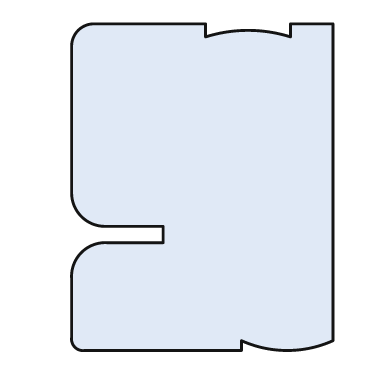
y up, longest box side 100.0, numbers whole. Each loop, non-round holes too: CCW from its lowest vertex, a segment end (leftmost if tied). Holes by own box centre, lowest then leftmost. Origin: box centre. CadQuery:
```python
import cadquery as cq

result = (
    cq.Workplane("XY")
    .moveTo(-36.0, -50.0)
    .lineTo(12.0, -50.0)
    .lineTo(12.0, -47.0)
    .threePointArc((26.0, -50.0), (40.0, -47.0))
    .lineTo(40.0, 50.0)
    .lineTo(27.0, 50.0)
    .lineTo(27.0, 46.0)
    .threePointArc((14.0, 48.0), (1.0, 46.0))
    .lineTo(1.0, 50.0)
    .lineTo(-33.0, 50.0)
    .threePointArc((-38.0, 48.0), (-40.0, 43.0))
    .lineTo(-40.0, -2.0)
    .threePointArc((-37.0, -9.0), (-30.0, -12.0))
    .lineTo(-12.0, -12.0)
    .lineTo(-12.0, -17.0)
    .lineTo(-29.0, -17.0)
    .threePointArc((-37.0, -20.0), (-40.0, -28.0))
    .lineTo(-40.0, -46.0)
    .threePointArc((-39.0, -49.0), (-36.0, -50.0))
    .close()
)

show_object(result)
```